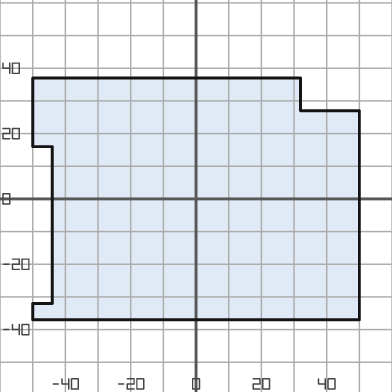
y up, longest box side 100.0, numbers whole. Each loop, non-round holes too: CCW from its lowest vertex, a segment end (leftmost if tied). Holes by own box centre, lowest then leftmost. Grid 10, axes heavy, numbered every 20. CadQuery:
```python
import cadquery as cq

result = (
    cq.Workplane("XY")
    .moveTo(-50.0, -37.0)
    .lineTo(50.0, -37.0)
    .lineTo(50.0, 27.0)
    .lineTo(32.0, 27.0)
    .lineTo(32.0, 37.0)
    .lineTo(-50.0, 37.0)
    .lineTo(-50.0, 16.0)
    .lineTo(-44.0, 16.0)
    .lineTo(-44.0, -32.0)
    .lineTo(-50.0, -32.0)
    .close()
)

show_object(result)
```